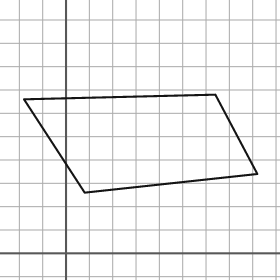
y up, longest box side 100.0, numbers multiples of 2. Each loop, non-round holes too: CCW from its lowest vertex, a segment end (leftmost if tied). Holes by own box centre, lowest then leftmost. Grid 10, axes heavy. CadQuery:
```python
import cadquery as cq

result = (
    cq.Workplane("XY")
    .moveTo(8.0, 26.0)
    .lineTo(82.0, 34.0)
    .lineTo(64.0, 68.0)
    .lineTo(-18.0, 66.0)
    .close()
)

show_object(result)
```